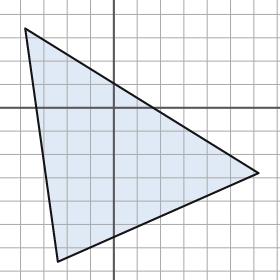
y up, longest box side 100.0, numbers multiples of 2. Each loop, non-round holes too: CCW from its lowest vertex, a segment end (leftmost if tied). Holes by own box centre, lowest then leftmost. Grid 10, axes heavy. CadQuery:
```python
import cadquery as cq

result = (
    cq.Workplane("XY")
    .moveTo(-24.0, -66.0)
    .lineTo(62.0, -28.0)
    .lineTo(-38.0, 34.0)
    .close()
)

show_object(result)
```